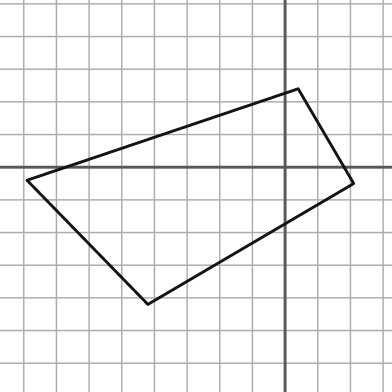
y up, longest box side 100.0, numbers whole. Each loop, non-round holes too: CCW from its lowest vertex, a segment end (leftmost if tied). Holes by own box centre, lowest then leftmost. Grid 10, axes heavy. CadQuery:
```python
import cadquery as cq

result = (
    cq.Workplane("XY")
    .moveTo(-42.0, -42.0)
    .lineTo(21.0, -5.0)
    .lineTo(4.0, 24.0)
    .lineTo(-79.0, -4.0)
    .close()
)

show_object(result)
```